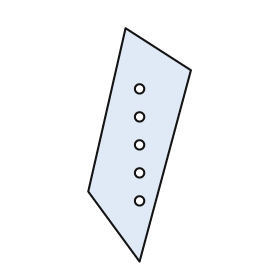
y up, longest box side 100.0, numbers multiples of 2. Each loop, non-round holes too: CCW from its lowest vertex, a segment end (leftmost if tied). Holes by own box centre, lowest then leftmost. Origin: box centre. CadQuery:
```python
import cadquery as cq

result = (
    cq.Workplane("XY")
    .moveTo(0.0, -50.0)
    .lineTo(22.0, 32.0)
    .lineTo(-6.0, 50.0)
    .lineTo(-22.0, -20.0)
    .close()
    .moveTo(0.0, -24.0)
    .circle(2.0)
    .moveTo(0.0, -12.0)
    .circle(2.0)
    .moveTo(0.0, 0.0)
    .circle(2.0)
    .moveTo(0.0, 12.0)
    .circle(2.0)
    .moveTo(0.0, 24.0)
    .circle(2.0)
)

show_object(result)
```